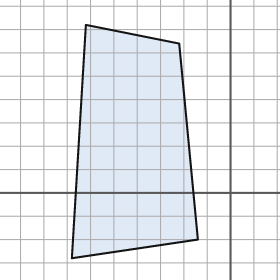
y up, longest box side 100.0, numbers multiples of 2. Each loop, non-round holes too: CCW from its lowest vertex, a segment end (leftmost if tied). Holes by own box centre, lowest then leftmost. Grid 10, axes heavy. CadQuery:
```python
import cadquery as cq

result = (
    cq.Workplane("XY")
    .moveTo(-68.0, -28.0)
    .lineTo(-14.0, -20.0)
    .lineTo(-22.0, 64.0)
    .lineTo(-62.0, 72.0)
    .close()
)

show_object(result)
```